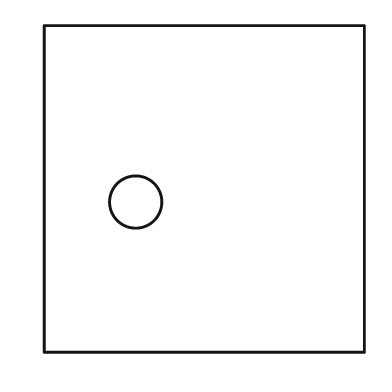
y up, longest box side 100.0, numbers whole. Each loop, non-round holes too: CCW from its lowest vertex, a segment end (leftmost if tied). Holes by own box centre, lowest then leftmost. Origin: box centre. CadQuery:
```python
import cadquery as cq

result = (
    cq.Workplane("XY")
    .moveTo(-49.0, -50.0)
    .lineTo(49.0, -50.0)
    .lineTo(49.0, 50.0)
    .lineTo(-49.0, 50.0)
    .close()
    .moveTo(-21.0, -4.0)
    .circle(8.0)
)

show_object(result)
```